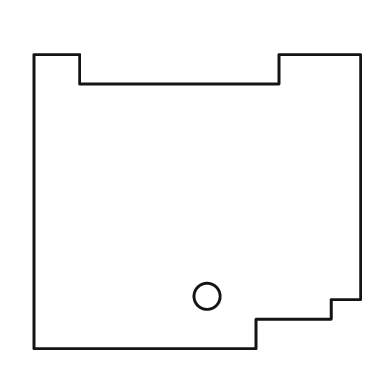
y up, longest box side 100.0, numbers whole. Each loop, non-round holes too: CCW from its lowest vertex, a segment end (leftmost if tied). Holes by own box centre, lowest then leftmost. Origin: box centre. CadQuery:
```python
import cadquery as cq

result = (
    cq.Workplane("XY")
    .moveTo(-50.0, -45.0)
    .lineTo(18.0, -45.0)
    .lineTo(18.0, -36.0)
    .lineTo(41.0, -36.0)
    .lineTo(41.0, -30.0)
    .lineTo(50.0, -30.0)
    .lineTo(50.0, 45.0)
    .lineTo(25.0, 45.0)
    .lineTo(25.0, 36.0)
    .lineTo(-36.0, 36.0)
    .lineTo(-36.0, 45.0)
    .lineTo(-50.0, 45.0)
    .close()
    .moveTo(3.0, -29.0)
    .circle(4.0)
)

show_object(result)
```